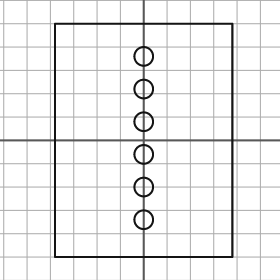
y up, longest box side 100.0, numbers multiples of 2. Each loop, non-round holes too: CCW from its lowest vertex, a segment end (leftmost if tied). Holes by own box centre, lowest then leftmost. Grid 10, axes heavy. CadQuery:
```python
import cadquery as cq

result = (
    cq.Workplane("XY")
    .moveTo(-38.0, -50.0)
    .lineTo(38.0, -50.0)
    .lineTo(38.0, 50.0)
    .lineTo(-38.0, 50.0)
    .close()
    .moveTo(0.0, -34.0)
    .circle(4.0)
    .moveTo(0.0, -20.0)
    .circle(4.0)
    .moveTo(0.0, -6.0)
    .circle(4.0)
    .moveTo(0.0, 8.0)
    .circle(4.0)
    .moveTo(0.0, 22.0)
    .circle(4.0)
    .moveTo(0.0, 36.0)
    .circle(4.0)
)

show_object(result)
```